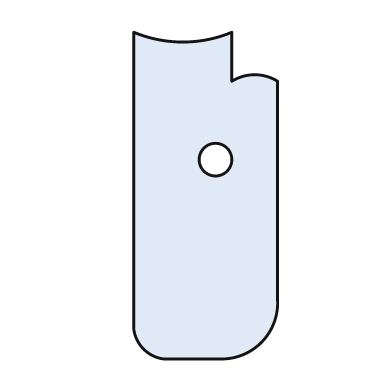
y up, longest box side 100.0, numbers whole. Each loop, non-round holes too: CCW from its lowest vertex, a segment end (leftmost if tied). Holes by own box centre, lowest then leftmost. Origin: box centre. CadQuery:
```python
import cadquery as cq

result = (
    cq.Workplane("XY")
    .moveTo(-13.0, -50.0)
    .lineTo(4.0, -50.0)
    .threePointArc((17.0, -45.0), (22.0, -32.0))
    .lineTo(22.0, 35.0)
    .threePointArc((15.0, 37.0), (8.0, 35.0))
    .lineTo(8.0, 50.0)
    .threePointArc((-7.0, 47.0), (-22.0, 50.0))
    .lineTo(-22.0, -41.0)
    .threePointArc((-19.0, -47.0), (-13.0, -50.0))
    .close()
    .moveTo(3.0, 11.0)
    .circle(5.0)
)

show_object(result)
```